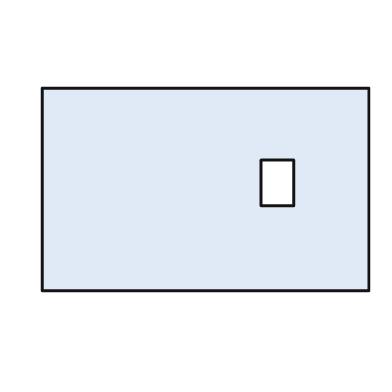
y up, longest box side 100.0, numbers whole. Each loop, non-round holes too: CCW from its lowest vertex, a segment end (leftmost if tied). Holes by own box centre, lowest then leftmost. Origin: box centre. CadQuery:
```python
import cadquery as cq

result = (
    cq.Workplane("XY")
    .moveTo(-50.0, -31.0)
    .lineTo(50.0, -31.0)
    .lineTo(50.0, 31.0)
    .lineTo(-50.0, 31.0)
    .close()
    .moveTo(17.0, -5.0)
    .lineTo(27.0, -5.0)
    .lineTo(27.0, 9.0)
    .lineTo(17.0, 9.0)
    .close()
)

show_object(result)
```